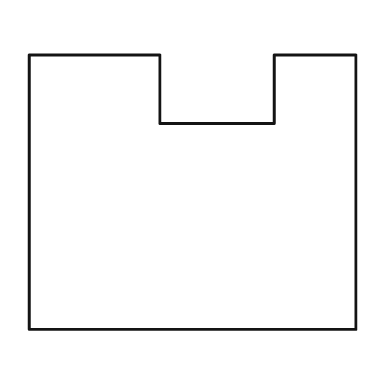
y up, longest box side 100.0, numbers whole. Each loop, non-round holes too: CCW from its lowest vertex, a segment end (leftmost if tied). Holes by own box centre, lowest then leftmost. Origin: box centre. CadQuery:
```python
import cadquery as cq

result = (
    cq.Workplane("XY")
    .moveTo(-50.0, -42.0)
    .lineTo(50.0, -42.0)
    .lineTo(50.0, 42.0)
    .lineTo(25.0, 42.0)
    .lineTo(25.0, 21.0)
    .lineTo(-10.0, 21.0)
    .lineTo(-10.0, 42.0)
    .lineTo(-50.0, 42.0)
    .close()
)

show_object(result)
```